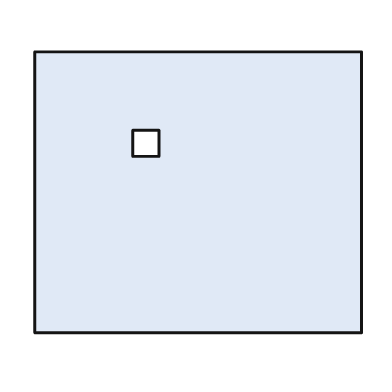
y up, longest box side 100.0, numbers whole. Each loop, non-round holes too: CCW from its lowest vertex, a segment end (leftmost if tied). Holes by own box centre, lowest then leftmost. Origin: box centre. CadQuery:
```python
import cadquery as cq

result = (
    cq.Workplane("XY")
    .moveTo(-50.0, -43.0)
    .lineTo(50.0, -43.0)
    .lineTo(50.0, 43.0)
    .lineTo(-50.0, 43.0)
    .close()
    .moveTo(-20.0, 11.0)
    .lineTo(-12.0, 11.0)
    .lineTo(-12.0, 19.0)
    .lineTo(-20.0, 19.0)
    .close()
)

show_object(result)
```